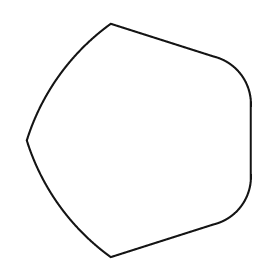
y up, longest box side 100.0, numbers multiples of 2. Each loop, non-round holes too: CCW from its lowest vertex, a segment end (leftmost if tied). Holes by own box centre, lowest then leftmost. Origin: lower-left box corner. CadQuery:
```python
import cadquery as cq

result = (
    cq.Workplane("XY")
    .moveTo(36.0, 0.0)
    .lineTo(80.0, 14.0)
    .threePointArc((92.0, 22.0), (96.0, 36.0))
    .lineTo(96.0, 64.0)
    .threePointArc((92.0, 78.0), (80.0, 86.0))
    .lineTo(36.0, 100.0)
    .threePointArc((14.0, 78.0), (0.0, 50.0))
    .threePointArc((14.0, 22.0), (36.0, 0.0))
    .close()
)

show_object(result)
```